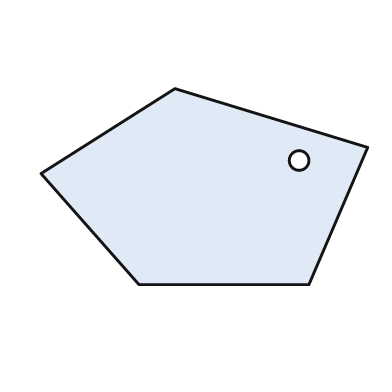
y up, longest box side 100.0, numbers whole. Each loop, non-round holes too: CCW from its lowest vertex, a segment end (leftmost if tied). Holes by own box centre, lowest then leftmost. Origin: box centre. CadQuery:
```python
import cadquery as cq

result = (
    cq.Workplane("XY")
    .moveTo(-20.0, -30.0)
    .lineTo(32.0, -30.0)
    .lineTo(50.0, 12.0)
    .lineTo(-9.0, 30.0)
    .lineTo(-50.0, 4.0)
    .close()
    .moveTo(29.0, 8.0)
    .circle(3.0)
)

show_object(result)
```